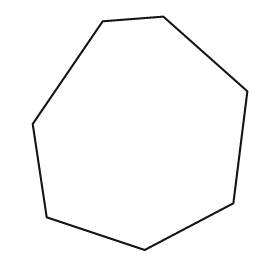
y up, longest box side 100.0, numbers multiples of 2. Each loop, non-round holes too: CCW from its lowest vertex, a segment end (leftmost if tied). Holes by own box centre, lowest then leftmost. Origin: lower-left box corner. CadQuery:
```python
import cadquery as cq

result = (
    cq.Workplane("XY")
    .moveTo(48.0, 0.0)
    .lineTo(86.0, 20.0)
    .lineTo(92.0, 68.0)
    .lineTo(56.0, 100.0)
    .lineTo(30.0, 98.0)
    .lineTo(0.0, 54.0)
    .lineTo(6.0, 14.0)
    .close()
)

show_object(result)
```